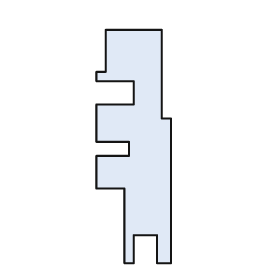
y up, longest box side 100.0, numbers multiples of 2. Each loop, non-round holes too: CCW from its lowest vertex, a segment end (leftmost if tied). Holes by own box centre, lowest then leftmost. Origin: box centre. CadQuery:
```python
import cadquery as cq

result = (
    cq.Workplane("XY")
    .moveTo(-4.0, -50.0)
    .lineTo(0.0, -50.0)
    .lineTo(0.0, -38.0)
    .lineTo(10.0, -38.0)
    .lineTo(10.0, -50.0)
    .lineTo(16.0, -50.0)
    .lineTo(16.0, 12.0)
    .lineTo(12.0, 12.0)
    .lineTo(12.0, 50.0)
    .lineTo(-12.0, 50.0)
    .lineTo(-12.0, 32.0)
    .lineTo(-16.0, 32.0)
    .lineTo(-16.0, 28.0)
    .lineTo(0.0, 28.0)
    .lineTo(0.0, 18.0)
    .lineTo(-16.0, 18.0)
    .lineTo(-16.0, 2.0)
    .lineTo(-2.0, 2.0)
    .lineTo(-2.0, -4.0)
    .lineTo(-16.0, -4.0)
    .lineTo(-16.0, -18.0)
    .lineTo(-4.0, -18.0)
    .close()
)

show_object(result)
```